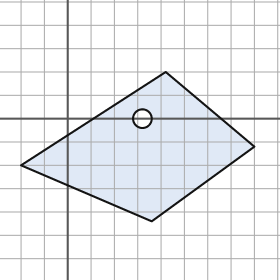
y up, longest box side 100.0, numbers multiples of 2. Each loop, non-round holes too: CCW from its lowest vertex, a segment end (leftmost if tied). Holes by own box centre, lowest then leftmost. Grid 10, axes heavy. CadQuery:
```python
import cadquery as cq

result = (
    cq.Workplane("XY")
    .moveTo(36.0, -44.0)
    .lineTo(80.0, -12.0)
    .lineTo(42.0, 20.0)
    .lineTo(-20.0, -20.0)
    .close()
    .moveTo(32.0, 0.0)
    .circle(4.0)
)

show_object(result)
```